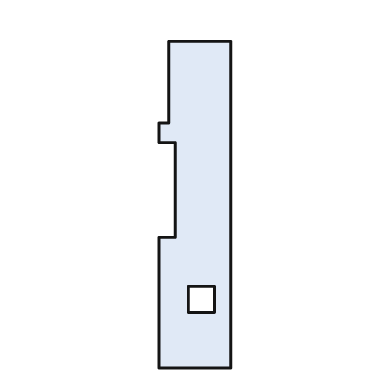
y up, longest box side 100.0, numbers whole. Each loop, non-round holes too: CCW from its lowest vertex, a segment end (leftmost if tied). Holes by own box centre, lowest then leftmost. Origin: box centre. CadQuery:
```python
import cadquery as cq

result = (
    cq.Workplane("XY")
    .moveTo(-11.0, -50.0)
    .lineTo(11.0, -50.0)
    .lineTo(11.0, 50.0)
    .lineTo(-8.0, 50.0)
    .lineTo(-8.0, 25.0)
    .lineTo(-11.0, 25.0)
    .lineTo(-11.0, 19.0)
    .lineTo(-6.0, 19.0)
    .lineTo(-6.0, -10.0)
    .lineTo(-11.0, -10.0)
    .close()
    .moveTo(-2.0, -33.0)
    .lineTo(6.0, -33.0)
    .lineTo(6.0, -25.0)
    .lineTo(-2.0, -25.0)
    .close()
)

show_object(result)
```